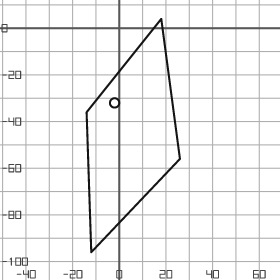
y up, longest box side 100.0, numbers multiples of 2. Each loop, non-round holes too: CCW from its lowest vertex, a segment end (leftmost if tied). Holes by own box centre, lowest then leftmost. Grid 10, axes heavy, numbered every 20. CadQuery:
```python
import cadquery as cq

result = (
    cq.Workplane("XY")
    .moveTo(-12.0, -96.0)
    .lineTo(26.0, -56.0)
    .lineTo(18.0, 4.0)
    .lineTo(-14.0, -36.0)
    .close()
    .moveTo(-2.0, -32.0)
    .circle(2.0)
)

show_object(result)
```